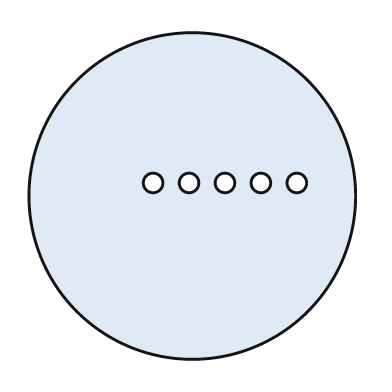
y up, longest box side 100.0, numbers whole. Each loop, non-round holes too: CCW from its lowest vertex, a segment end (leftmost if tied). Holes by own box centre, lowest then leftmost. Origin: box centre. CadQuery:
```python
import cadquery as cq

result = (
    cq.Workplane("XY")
    .moveTo(0.0, 0.0)
    .circle(50.0)
    .moveTo(-12.0, 4.0)
    .circle(3.0)
    .moveTo(-1.0, 4.0)
    .circle(3.0)
    .moveTo(10.0, 4.0)
    .circle(3.0)
    .moveTo(21.0, 4.0)
    .circle(3.0)
    .moveTo(32.0, 4.0)
    .circle(3.0)
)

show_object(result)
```